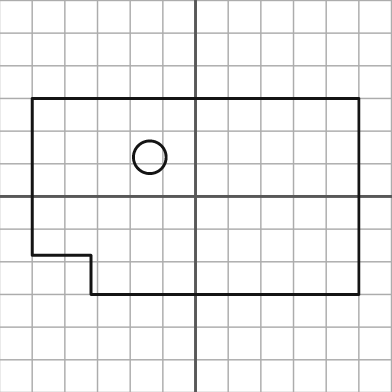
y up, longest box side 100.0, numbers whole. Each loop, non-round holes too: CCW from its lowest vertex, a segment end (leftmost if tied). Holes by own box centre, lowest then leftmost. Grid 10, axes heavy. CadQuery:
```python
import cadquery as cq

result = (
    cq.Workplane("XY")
    .moveTo(-32.0, -30.0)
    .lineTo(50.0, -30.0)
    .lineTo(50.0, 30.0)
    .lineTo(-50.0, 30.0)
    .lineTo(-50.0, -18.0)
    .lineTo(-32.0, -18.0)
    .close()
    .moveTo(-14.0, 12.0)
    .circle(5.0)
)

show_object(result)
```